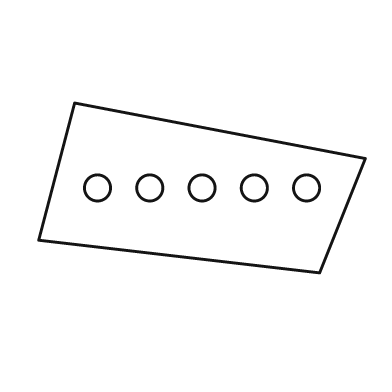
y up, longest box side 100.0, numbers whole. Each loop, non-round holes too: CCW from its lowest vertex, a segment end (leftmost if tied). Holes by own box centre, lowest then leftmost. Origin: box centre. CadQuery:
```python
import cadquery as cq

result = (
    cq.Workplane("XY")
    .moveTo(36.0, -26.0)
    .lineTo(50.0, 9.0)
    .lineTo(-39.0, 26.0)
    .lineTo(-50.0, -16.0)
    .close()
    .moveTo(-32.0, 0.0)
    .circle(4.0)
    .moveTo(-16.0, 0.0)
    .circle(4.0)
    .moveTo(0.0, 0.0)
    .circle(4.0)
    .moveTo(16.0, 0.0)
    .circle(4.0)
    .moveTo(32.0, 0.0)
    .circle(4.0)
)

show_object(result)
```